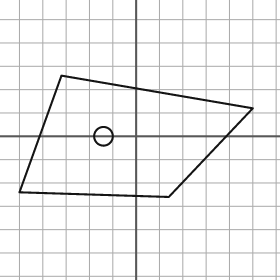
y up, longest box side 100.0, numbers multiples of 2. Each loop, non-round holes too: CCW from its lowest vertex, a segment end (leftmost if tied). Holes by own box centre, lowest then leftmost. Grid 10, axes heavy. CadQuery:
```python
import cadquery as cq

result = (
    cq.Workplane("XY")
    .moveTo(14.0, -26.0)
    .lineTo(50.0, 12.0)
    .lineTo(-32.0, 26.0)
    .lineTo(-50.0, -24.0)
    .close()
    .moveTo(-14.0, 0.0)
    .circle(4.0)
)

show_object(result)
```